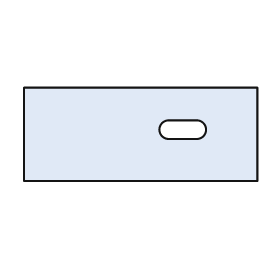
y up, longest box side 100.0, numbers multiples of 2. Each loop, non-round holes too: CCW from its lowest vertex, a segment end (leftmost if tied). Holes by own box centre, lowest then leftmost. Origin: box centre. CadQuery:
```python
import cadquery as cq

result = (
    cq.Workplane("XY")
    .moveTo(-50.0, -20.0)
    .lineTo(50.0, -20.0)
    .lineTo(50.0, 20.0)
    .lineTo(-50.0, 20.0)
    .close()
    .moveTo(12.0, -2.0)
    .lineTo(24.0, -2.0)
    .threePointArc((28.0, 2.0), (24.0, 6.0))
    .lineTo(12.0, 6.0)
    .threePointArc((8.0, 2.0), (12.0, -2.0))
    .close()
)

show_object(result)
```